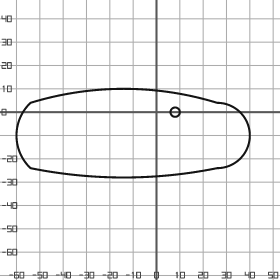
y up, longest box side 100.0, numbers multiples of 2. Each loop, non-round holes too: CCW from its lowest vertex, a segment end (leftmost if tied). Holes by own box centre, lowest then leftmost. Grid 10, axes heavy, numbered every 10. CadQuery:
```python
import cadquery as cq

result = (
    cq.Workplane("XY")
    .moveTo(-54.0, -24.0)
    .threePointArc((-14.0, -28.0), (26.0, -24.0))
    .threePointArc((40.0, -10.0), (26.0, 4.0))
    .threePointArc((-14.0, 10.0), (-54.0, 4.0))
    .threePointArc((-60.0, -10.0), (-54.0, -24.0))
    .close()
    .moveTo(8.0, 0.0)
    .circle(2.0)
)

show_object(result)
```